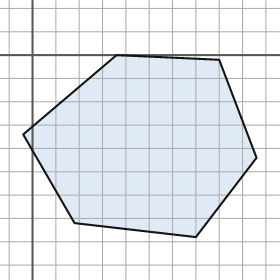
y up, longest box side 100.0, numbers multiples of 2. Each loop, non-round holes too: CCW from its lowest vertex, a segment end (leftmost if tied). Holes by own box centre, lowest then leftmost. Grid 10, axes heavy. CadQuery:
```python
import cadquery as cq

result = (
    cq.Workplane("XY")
    .moveTo(70.0, -78.0)
    .lineTo(96.0, -44.0)
    .lineTo(80.0, -2.0)
    .lineTo(36.0, 0.0)
    .lineTo(-4.0, -34.0)
    .lineTo(18.0, -72.0)
    .close()
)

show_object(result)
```